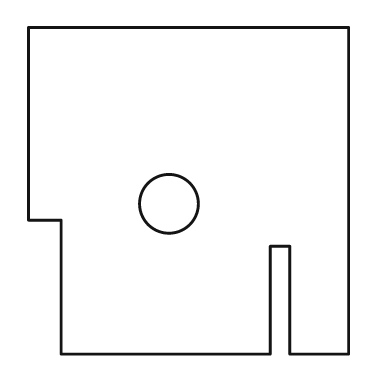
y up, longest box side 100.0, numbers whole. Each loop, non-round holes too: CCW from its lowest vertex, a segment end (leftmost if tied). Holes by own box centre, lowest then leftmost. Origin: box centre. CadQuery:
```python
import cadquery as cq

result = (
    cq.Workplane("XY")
    .moveTo(-39.0, -50.0)
    .lineTo(25.0, -50.0)
    .lineTo(25.0, -17.0)
    .lineTo(31.0, -17.0)
    .lineTo(31.0, -50.0)
    .lineTo(49.0, -50.0)
    .lineTo(49.0, 50.0)
    .lineTo(-49.0, 50.0)
    .lineTo(-49.0, -9.0)
    .lineTo(-39.0, -9.0)
    .close()
    .moveTo(-6.0, -4.0)
    .circle(9.0)
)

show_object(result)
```